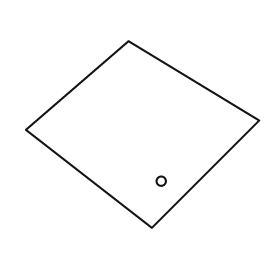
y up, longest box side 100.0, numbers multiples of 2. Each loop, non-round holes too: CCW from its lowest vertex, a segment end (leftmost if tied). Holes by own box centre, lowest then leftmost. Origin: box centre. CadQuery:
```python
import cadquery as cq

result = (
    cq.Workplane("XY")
    .moveTo(4.0, -40.0)
    .lineTo(50.0, 6.0)
    .lineTo(-6.0, 40.0)
    .lineTo(-50.0, 2.0)
    .close()
    .moveTo(8.0, -20.0)
    .circle(2.0)
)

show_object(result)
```